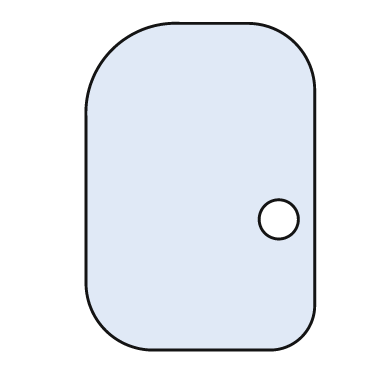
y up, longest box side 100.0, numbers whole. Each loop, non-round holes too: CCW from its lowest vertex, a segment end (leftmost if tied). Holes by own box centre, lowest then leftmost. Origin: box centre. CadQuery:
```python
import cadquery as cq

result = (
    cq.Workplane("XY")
    .moveTo(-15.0, -50.0)
    .lineTo(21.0, -50.0)
    .threePointArc((31.0, -46.0), (35.0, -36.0))
    .lineTo(35.0, 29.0)
    .threePointArc((29.0, 44.0), (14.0, 50.0))
    .lineTo(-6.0, 50.0)
    .threePointArc((-27.0, 42.0), (-35.0, 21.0))
    .lineTo(-35.0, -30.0)
    .threePointArc((-29.0, -44.0), (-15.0, -50.0))
    .close()
    .moveTo(24.0, -10.0)
    .circle(6.0)
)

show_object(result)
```